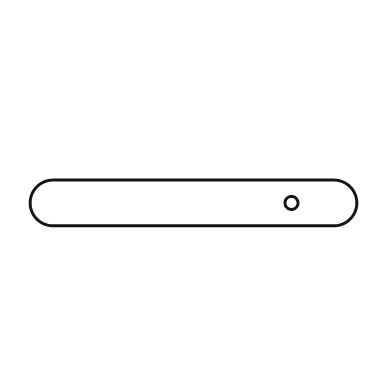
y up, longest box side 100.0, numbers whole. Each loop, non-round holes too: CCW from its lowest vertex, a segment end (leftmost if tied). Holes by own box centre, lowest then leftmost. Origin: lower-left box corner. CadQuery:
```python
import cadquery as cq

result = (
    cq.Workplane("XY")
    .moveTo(7.0, 0.0)
    .lineTo(93.0, 0.0)
    .threePointArc((100.0, 7.0), (93.0, 14.0))
    .lineTo(7.0, 14.0)
    .threePointArc((0.0, 7.0), (7.0, 0.0))
    .close()
    .moveTo(80.0, 7.0)
    .circle(2.0)
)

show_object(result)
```